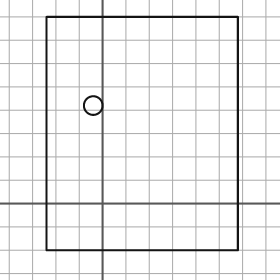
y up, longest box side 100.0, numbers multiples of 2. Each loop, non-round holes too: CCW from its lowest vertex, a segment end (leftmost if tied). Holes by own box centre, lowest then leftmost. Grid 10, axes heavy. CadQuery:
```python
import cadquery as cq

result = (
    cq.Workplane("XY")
    .moveTo(-24.0, -20.0)
    .lineTo(58.0, -20.0)
    .lineTo(58.0, 80.0)
    .lineTo(-24.0, 80.0)
    .close()
    .moveTo(-4.0, 42.0)
    .circle(4.0)
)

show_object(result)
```